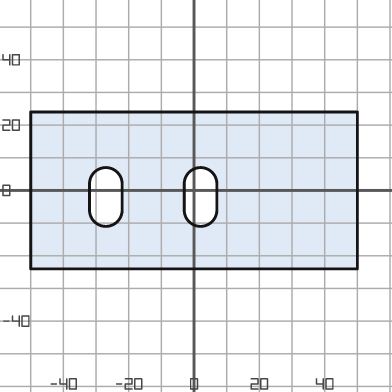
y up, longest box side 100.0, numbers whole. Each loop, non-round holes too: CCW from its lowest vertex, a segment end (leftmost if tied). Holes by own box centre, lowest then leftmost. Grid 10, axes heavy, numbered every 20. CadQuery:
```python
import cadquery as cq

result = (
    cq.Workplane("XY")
    .moveTo(-50.0, -24.0)
    .lineTo(50.0, -24.0)
    .lineTo(50.0, 24.0)
    .lineTo(-50.0, 24.0)
    .close()
    .moveTo(-32.0, -6.0)
    .threePointArc((-27.0, -11.0), (-22.0, -6.0))
    .lineTo(-22.0, 2.0)
    .threePointArc((-27.0, 7.0), (-32.0, 2.0))
    .close()
    .moveTo(-3.0, -6.0)
    .threePointArc((2.0, -11.0), (7.0, -6.0))
    .lineTo(7.0, 2.0)
    .threePointArc((2.0, 7.0), (-3.0, 2.0))
    .close()
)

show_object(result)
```